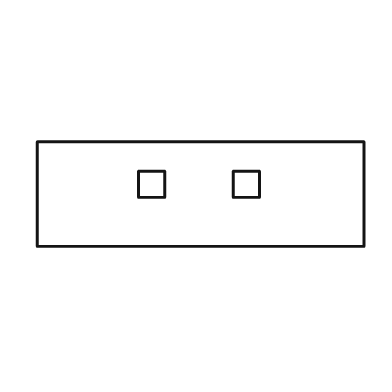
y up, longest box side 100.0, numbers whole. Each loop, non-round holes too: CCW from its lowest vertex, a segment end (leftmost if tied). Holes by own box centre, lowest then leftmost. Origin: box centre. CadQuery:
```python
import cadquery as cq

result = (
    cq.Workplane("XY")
    .moveTo(-50.0, -16.0)
    .lineTo(50.0, -16.0)
    .lineTo(50.0, 16.0)
    .lineTo(-50.0, 16.0)
    .close()
    .moveTo(-19.0, -1.0)
    .lineTo(-11.0, -1.0)
    .lineTo(-11.0, 7.0)
    .lineTo(-19.0, 7.0)
    .close()
    .moveTo(10.0, -1.0)
    .lineTo(18.0, -1.0)
    .lineTo(18.0, 7.0)
    .lineTo(10.0, 7.0)
    .close()
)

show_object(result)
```